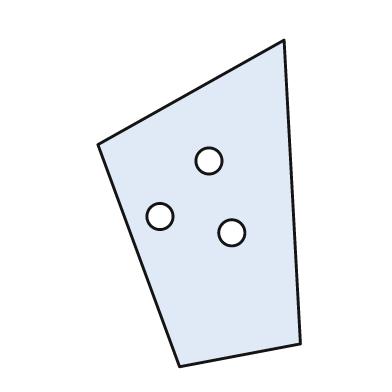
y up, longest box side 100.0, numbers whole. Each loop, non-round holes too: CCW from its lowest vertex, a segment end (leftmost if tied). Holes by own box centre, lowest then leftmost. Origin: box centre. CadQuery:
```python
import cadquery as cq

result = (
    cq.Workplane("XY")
    .moveTo(-6.0, -50.0)
    .lineTo(31.0, -43.0)
    .lineTo(26.0, 50.0)
    .lineTo(-31.0, 18.0)
    .close()
    .moveTo(10.0, -9.0)
    .circle(4.0)
    .moveTo(-12.0, -4.0)
    .circle(4.0)
    .moveTo(3.0, 13.0)
    .circle(4.0)
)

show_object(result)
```